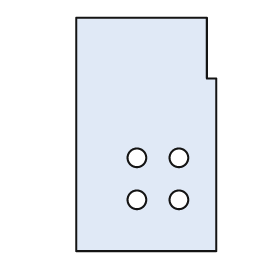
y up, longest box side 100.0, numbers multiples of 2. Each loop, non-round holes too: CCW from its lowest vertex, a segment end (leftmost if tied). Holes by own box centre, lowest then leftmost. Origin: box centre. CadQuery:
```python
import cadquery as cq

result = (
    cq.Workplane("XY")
    .moveTo(-30.0, -50.0)
    .lineTo(30.0, -50.0)
    .lineTo(30.0, 24.0)
    .lineTo(26.0, 24.0)
    .lineTo(26.0, 50.0)
    .lineTo(-30.0, 50.0)
    .close()
    .moveTo(-4.0, -28.0)
    .circle(4.0)
    .moveTo(14.0, -28.0)
    .circle(4.0)
    .moveTo(-4.0, -10.0)
    .circle(4.0)
    .moveTo(14.0, -10.0)
    .circle(4.0)
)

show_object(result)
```